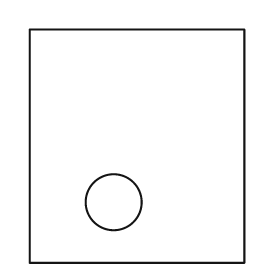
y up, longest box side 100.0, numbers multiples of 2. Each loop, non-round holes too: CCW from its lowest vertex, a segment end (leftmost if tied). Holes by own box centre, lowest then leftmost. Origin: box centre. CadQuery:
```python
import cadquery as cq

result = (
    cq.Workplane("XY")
    .moveTo(-46.0, -50.0)
    .lineTo(46.0, -50.0)
    .lineTo(46.0, 50.0)
    .lineTo(-46.0, 50.0)
    .close()
    .moveTo(-10.0, -24.0)
    .circle(12.0)
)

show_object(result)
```